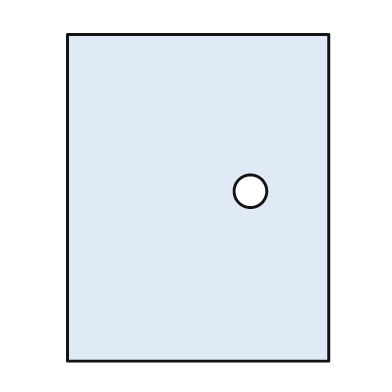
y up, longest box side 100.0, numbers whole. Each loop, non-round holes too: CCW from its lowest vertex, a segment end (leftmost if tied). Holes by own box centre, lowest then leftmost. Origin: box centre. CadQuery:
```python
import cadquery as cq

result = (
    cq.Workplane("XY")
    .moveTo(-40.0, -50.0)
    .lineTo(40.0, -50.0)
    .lineTo(40.0, 50.0)
    .lineTo(-40.0, 50.0)
    .close()
    .moveTo(16.0, 2.0)
    .circle(5.0)
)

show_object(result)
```